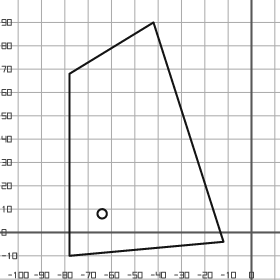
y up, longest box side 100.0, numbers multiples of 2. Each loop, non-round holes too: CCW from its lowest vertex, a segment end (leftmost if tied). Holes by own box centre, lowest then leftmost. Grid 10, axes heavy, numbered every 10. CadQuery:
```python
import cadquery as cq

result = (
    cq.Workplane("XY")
    .moveTo(-78.0, -10.0)
    .lineTo(-12.0, -4.0)
    .lineTo(-42.0, 90.0)
    .lineTo(-78.0, 68.0)
    .close()
    .moveTo(-64.0, 8.0)
    .circle(2.0)
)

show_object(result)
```